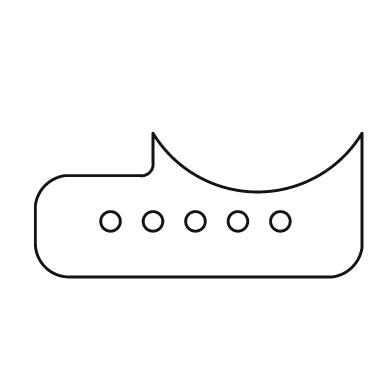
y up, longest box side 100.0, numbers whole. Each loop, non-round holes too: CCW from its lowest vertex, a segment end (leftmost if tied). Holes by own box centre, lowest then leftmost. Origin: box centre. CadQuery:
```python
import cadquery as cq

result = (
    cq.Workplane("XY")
    .moveTo(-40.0, -22.0)
    .lineTo(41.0, -22.0)
    .threePointArc((47.0, -19.0), (50.0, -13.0))
    .lineTo(50.0, 22.0)
    .threePointArc((18.0, 4.0), (-14.0, 22.0))
    .lineTo(-14.0, 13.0)
    .threePointArc((-15.0, 10.0), (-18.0, 9.0))
    .lineTo(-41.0, 9.0)
    .threePointArc((-47.0, 6.0), (-50.0, 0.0))
    .lineTo(-50.0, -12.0)
    .threePointArc((-47.0, -19.0), (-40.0, -22.0))
    .close()
    .moveTo(-27.0, -5.0)
    .circle(3.0)
    .moveTo(-14.0, -5.0)
    .circle(3.0)
    .moveTo(-1.0, -5.0)
    .circle(3.0)
    .moveTo(12.0, -5.0)
    .circle(3.0)
    .moveTo(25.0, -5.0)
    .circle(3.0)
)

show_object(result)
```